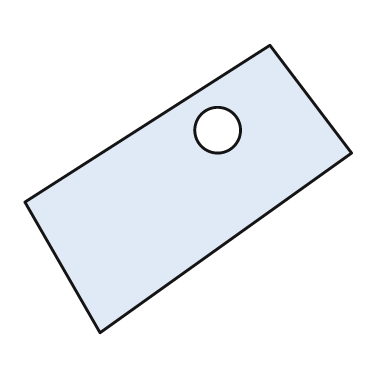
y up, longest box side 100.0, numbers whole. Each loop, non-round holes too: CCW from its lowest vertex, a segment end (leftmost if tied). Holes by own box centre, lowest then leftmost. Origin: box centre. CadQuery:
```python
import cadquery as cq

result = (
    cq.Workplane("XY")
    .moveTo(-27.0, -44.0)
    .lineTo(50.0, 11.0)
    .lineTo(25.0, 44.0)
    .lineTo(-50.0, -4.0)
    .close()
    .moveTo(9.0, 18.0)
    .circle(7.0)
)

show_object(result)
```